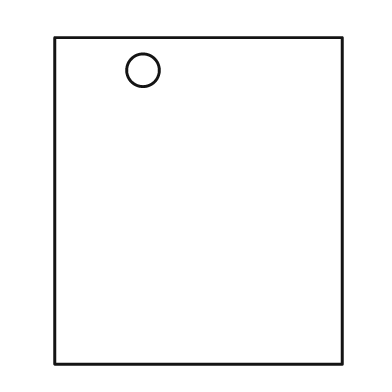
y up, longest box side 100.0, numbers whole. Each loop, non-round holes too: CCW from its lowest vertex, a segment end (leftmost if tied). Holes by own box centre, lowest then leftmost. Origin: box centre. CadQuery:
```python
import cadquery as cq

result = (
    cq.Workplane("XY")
    .moveTo(-44.0, -50.0)
    .lineTo(44.0, -50.0)
    .lineTo(44.0, 50.0)
    .lineTo(-44.0, 50.0)
    .close()
    .moveTo(-17.0, 40.0)
    .circle(5.0)
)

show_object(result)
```